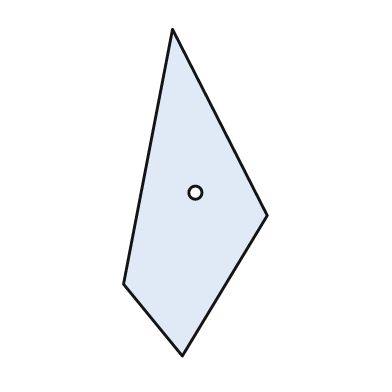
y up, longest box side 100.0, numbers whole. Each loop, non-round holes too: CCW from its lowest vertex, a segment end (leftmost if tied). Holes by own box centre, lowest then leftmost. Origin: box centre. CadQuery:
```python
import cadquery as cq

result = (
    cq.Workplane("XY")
    .moveTo(-4.0, -50.0)
    .lineTo(22.0, -7.0)
    .lineTo(-7.0, 50.0)
    .lineTo(-22.0, -28.0)
    .close()
    .moveTo(0.0, 0.0)
    .circle(2.0)
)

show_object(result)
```